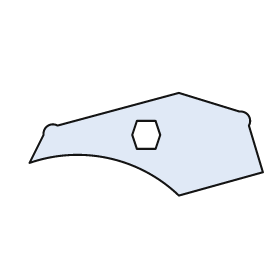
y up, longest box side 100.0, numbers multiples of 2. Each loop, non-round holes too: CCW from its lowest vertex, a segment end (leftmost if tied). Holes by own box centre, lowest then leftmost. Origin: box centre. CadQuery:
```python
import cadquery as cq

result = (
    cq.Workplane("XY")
    .moveTo(14.0, -22.0)
    .lineTo(50.0, -12.0)
    .lineTo(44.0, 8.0)
    .threePointArc((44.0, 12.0), (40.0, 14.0))
    .lineTo(14.0, 22.0)
    .lineTo(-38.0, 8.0)
    .threePointArc((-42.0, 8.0), (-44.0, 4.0))
    .lineTo(-50.0, -8.0)
    .threePointArc((-16.0, -6.0), (14.0, -22.0))
    .close()
    .moveTo(-4.0, -2.0)
    .lineTo(4.0, -2.0)
    .lineTo(6.0, 4.0)
    .lineTo(4.0, 10.0)
    .lineTo(-4.0, 10.0)
    .lineTo(-6.0, 4.0)
    .close()
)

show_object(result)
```